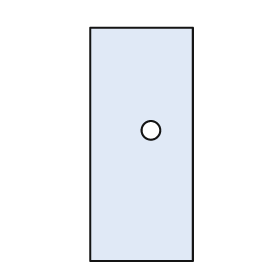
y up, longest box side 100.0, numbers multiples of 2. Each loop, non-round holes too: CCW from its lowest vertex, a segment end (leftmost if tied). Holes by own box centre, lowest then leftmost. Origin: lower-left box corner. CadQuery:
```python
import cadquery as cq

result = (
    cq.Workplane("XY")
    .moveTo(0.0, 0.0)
    .lineTo(44.0, 0.0)
    .lineTo(44.0, 100.0)
    .lineTo(0.0, 100.0)
    .close()
    .moveTo(26.0, 56.0)
    .circle(4.0)
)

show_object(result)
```